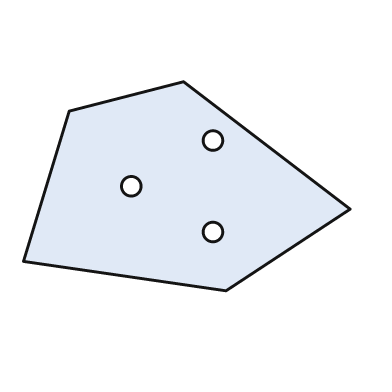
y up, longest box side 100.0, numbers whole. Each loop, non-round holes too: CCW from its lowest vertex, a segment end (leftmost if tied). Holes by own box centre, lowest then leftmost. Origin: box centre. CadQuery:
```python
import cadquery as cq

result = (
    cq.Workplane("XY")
    .moveTo(12.0, -32.0)
    .lineTo(50.0, -7.0)
    .lineTo(-1.0, 32.0)
    .lineTo(-36.0, 23.0)
    .lineTo(-50.0, -23.0)
    .close()
    .moveTo(8.0, -14.0)
    .circle(3.0)
    .moveTo(-17.0, 0.0)
    .circle(3.0)
    .moveTo(8.0, 14.0)
    .circle(3.0)
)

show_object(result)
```